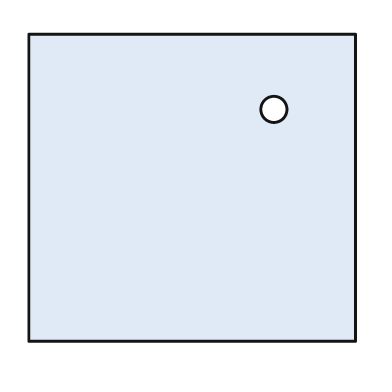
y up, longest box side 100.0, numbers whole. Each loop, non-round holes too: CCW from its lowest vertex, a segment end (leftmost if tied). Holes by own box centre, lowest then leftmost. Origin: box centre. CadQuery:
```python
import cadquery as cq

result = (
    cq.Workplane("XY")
    .moveTo(-50.0, -47.0)
    .lineTo(50.0, -47.0)
    .lineTo(50.0, 47.0)
    .lineTo(-50.0, 47.0)
    .close()
    .moveTo(25.0, 24.0)
    .circle(4.0)
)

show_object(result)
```